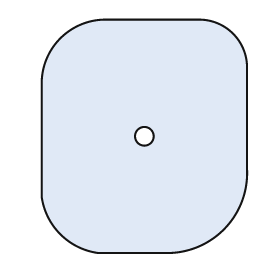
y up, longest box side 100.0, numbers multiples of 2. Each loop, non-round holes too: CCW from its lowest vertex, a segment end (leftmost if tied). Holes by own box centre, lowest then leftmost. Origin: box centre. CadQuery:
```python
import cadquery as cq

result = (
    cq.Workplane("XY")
    .moveTo(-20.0, -50.0)
    .lineTo(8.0, -50.0)
    .threePointArc((34.0, -40.0), (44.0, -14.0))
    .lineTo(44.0, 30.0)
    .threePointArc((38.0, 44.0), (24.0, 50.0))
    .lineTo(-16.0, 50.0)
    .threePointArc((-36.0, 42.0), (-44.0, 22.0))
    .lineTo(-44.0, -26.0)
    .threePointArc((-36.0, -42.0), (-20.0, -50.0))
    .close()
    .moveTo(0.0, 0.0)
    .circle(4.0)
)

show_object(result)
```